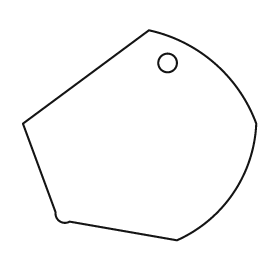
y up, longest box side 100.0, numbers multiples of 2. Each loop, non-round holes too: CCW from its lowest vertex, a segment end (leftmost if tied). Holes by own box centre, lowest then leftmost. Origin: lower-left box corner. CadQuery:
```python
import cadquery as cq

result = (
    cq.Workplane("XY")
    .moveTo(66.0, 0.0)
    .threePointArc((90.0, 20.0), (100.0, 50.0))
    .threePointArc((82.0, 76.0), (54.0, 90.0))
    .lineTo(0.0, 50.0)
    .lineTo(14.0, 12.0)
    .threePointArc((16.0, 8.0), (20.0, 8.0))
    .close()
    .moveTo(62.0, 76.0)
    .circle(4.0)
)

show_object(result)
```